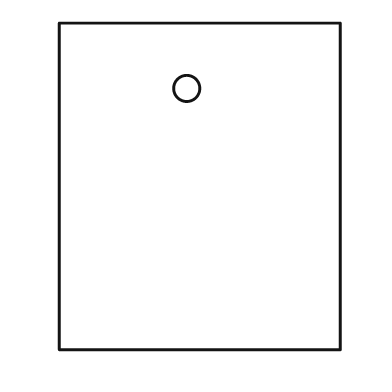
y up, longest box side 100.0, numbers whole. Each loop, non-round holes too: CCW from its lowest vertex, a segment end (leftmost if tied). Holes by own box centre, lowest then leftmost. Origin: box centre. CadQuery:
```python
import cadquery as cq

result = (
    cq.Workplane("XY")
    .moveTo(-43.0, -50.0)
    .lineTo(43.0, -50.0)
    .lineTo(43.0, 50.0)
    .lineTo(-43.0, 50.0)
    .close()
    .moveTo(-4.0, 30.0)
    .circle(4.0)
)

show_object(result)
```